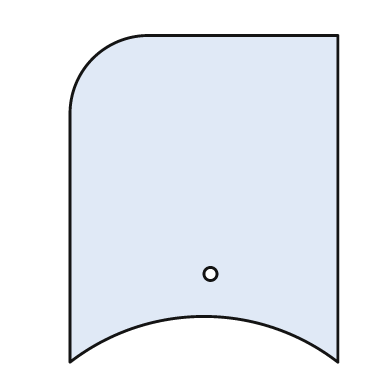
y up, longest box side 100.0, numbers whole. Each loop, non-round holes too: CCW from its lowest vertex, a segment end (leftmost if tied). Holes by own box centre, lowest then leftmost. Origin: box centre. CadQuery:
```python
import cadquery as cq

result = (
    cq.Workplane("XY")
    .moveTo(-41.0, -50.0)
    .threePointArc((0.0, -36.0), (41.0, -50.0))
    .lineTo(41.0, 50.0)
    .lineTo(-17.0, 50.0)
    .threePointArc((-34.0, 43.0), (-41.0, 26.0))
    .close()
    .moveTo(2.0, -23.0)
    .circle(2.0)
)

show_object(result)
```